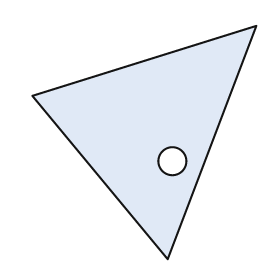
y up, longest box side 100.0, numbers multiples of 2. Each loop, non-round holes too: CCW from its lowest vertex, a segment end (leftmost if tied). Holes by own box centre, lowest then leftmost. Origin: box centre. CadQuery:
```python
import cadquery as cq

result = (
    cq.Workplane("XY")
    .moveTo(10.0, -50.0)
    .lineTo(48.0, 50.0)
    .lineTo(-48.0, 20.0)
    .close()
    .moveTo(12.0, -8.0)
    .circle(6.0)
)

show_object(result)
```